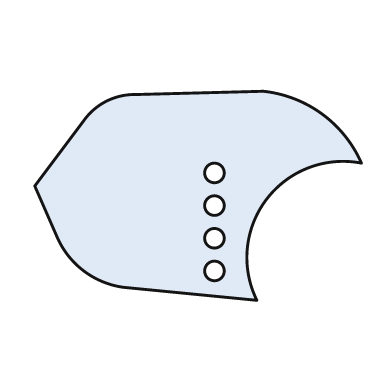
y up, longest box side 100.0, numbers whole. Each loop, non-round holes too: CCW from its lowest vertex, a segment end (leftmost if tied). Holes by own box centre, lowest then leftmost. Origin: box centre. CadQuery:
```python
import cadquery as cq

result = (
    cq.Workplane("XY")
    .moveTo(18.0, -32.0)
    .threePointArc((21.0, -1.0), (50.0, 10.0))
    .threePointArc((38.0, 25.0), (20.0, 32.0))
    .lineTo(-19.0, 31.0)
    .threePointArc((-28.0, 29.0), (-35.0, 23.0))
    .lineTo(-50.0, 3.0)
    .lineTo(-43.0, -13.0)
    .threePointArc((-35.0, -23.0), (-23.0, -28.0))
    .close()
    .moveTo(5.0, -23.0)
    .circle(3.0)
    .moveTo(5.0, -13.0)
    .circle(3.0)
    .moveTo(5.0, -3.0)
    .circle(3.0)
    .moveTo(5.0, 7.0)
    .circle(3.0)
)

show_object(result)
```